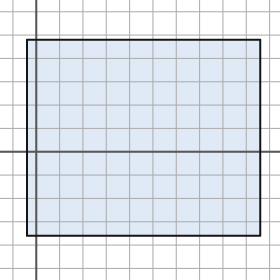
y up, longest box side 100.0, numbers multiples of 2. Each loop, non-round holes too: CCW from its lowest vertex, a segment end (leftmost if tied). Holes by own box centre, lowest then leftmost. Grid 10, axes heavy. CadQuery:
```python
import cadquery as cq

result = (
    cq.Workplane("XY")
    .moveTo(-4.0, -36.0)
    .lineTo(96.0, -36.0)
    .lineTo(96.0, 48.0)
    .lineTo(-4.0, 48.0)
    .close()
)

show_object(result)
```